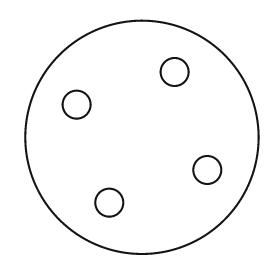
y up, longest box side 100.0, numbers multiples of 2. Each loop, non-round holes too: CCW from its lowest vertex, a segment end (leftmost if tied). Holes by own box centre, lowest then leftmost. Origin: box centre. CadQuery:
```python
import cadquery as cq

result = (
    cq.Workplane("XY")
    .moveTo(0.0, 0.0)
    .circle(50.0)
    .moveTo(-14.0, -28.0)
    .circle(6.0)
    .moveTo(28.0, -14.0)
    .circle(6.0)
    .moveTo(-28.0, 14.0)
    .circle(6.0)
    .moveTo(14.0, 28.0)
    .circle(6.0)
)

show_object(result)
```